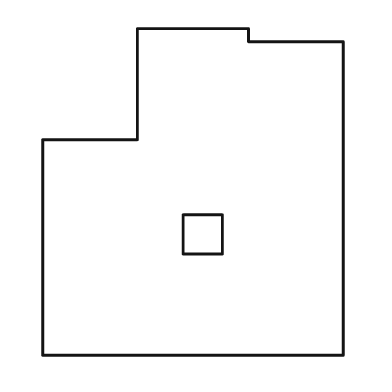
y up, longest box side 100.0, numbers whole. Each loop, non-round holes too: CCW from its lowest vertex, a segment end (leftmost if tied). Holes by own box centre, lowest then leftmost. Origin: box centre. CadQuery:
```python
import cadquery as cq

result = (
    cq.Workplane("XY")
    .moveTo(-46.0, -50.0)
    .lineTo(46.0, -50.0)
    .lineTo(46.0, 46.0)
    .lineTo(17.0, 46.0)
    .lineTo(17.0, 50.0)
    .lineTo(-17.0, 50.0)
    .lineTo(-17.0, 16.0)
    .lineTo(-46.0, 16.0)
    .close()
    .moveTo(-3.0, -19.0)
    .lineTo(9.0, -19.0)
    .lineTo(9.0, -7.0)
    .lineTo(-3.0, -7.0)
    .close()
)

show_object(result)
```